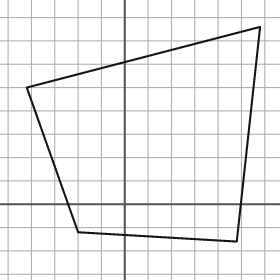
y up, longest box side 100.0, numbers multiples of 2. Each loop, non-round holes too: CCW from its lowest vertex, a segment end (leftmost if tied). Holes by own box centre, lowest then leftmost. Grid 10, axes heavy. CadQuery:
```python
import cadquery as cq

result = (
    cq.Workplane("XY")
    .moveTo(48.0, -16.0)
    .lineTo(58.0, 76.0)
    .lineTo(-42.0, 50.0)
    .lineTo(-20.0, -12.0)
    .close()
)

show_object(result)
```